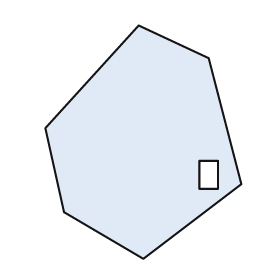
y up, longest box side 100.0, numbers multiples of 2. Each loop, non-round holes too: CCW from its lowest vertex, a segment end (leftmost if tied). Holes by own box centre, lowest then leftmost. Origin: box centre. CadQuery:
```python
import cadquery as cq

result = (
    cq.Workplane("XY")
    .moveTo(0.0, -50.0)
    .lineTo(42.0, -18.0)
    .lineTo(28.0, 36.0)
    .lineTo(-2.0, 50.0)
    .lineTo(-42.0, 6.0)
    .lineTo(-34.0, -30.0)
    .close()
    .moveTo(24.0, -20.0)
    .lineTo(32.0, -20.0)
    .lineTo(32.0, -8.0)
    .lineTo(24.0, -8.0)
    .close()
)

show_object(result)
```